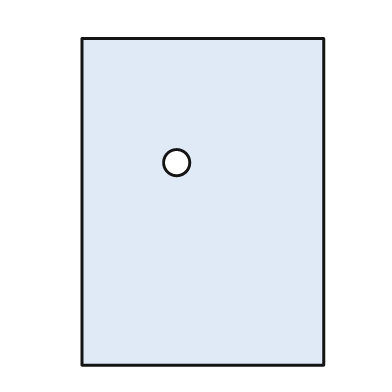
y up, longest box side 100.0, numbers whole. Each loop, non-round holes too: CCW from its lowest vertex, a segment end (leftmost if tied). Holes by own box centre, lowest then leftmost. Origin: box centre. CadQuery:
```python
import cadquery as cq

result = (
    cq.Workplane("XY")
    .moveTo(-37.0, -50.0)
    .lineTo(37.0, -50.0)
    .lineTo(37.0, 50.0)
    .lineTo(-37.0, 50.0)
    .close()
    .moveTo(-8.0, 12.0)
    .circle(4.0)
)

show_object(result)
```